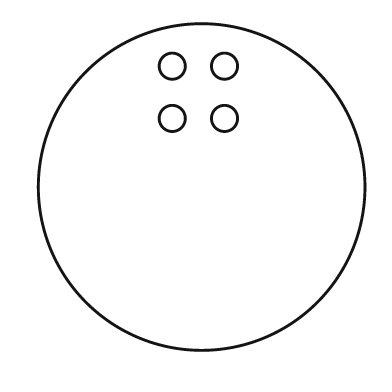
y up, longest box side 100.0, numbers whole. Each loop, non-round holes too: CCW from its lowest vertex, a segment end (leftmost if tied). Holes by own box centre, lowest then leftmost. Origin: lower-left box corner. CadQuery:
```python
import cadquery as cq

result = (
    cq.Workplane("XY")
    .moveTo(50.0, 50.0)
    .circle(50.0)
    .moveTo(41.0, 71.0)
    .circle(4.0)
    .moveTo(57.0, 71.0)
    .circle(4.0)
    .moveTo(41.0, 87.0)
    .circle(4.0)
    .moveTo(57.0, 87.0)
    .circle(4.0)
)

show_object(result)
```